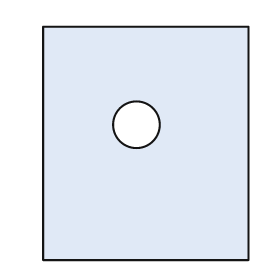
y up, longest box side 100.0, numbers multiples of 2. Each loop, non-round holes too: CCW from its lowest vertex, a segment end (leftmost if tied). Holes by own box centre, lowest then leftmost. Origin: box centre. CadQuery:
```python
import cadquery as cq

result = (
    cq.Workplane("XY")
    .moveTo(-44.0, -50.0)
    .lineTo(44.0, -50.0)
    .lineTo(44.0, 50.0)
    .lineTo(-44.0, 50.0)
    .close()
    .moveTo(-4.0, 8.0)
    .circle(10.0)
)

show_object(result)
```